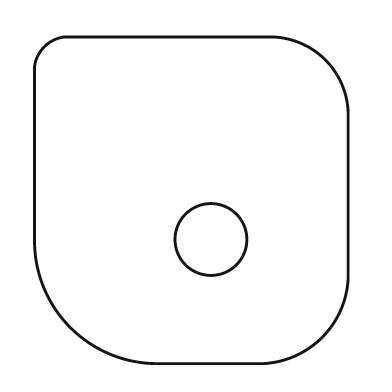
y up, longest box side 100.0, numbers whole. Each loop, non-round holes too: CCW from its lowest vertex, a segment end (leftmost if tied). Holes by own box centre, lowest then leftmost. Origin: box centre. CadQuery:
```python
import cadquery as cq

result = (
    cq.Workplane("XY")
    .moveTo(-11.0, -50.0)
    .lineTo(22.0, -50.0)
    .threePointArc((40.0, -42.0), (48.0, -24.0))
    .lineTo(48.0, 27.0)
    .threePointArc((41.0, 43.0), (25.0, 50.0))
    .lineTo(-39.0, 50.0)
    .threePointArc((-45.0, 47.0), (-48.0, 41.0))
    .lineTo(-48.0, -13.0)
    .threePointArc((-37.0, -39.0), (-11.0, -50.0))
    .close()
    .moveTo(6.0, -12.0)
    .circle(11.0)
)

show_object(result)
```